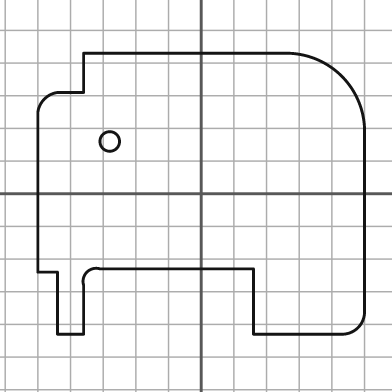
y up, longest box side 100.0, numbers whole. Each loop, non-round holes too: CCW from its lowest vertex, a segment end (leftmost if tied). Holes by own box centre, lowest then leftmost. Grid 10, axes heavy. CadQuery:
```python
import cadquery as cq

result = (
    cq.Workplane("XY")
    .moveTo(-44.0, -43.0)
    .lineTo(-36.0, -43.0)
    .lineTo(-36.0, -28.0)
    .threePointArc((-35.0, -24.0), (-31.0, -23.0))
    .lineTo(16.0, -23.0)
    .lineTo(16.0, -43.0)
    .lineTo(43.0, -43.0)
    .threePointArc((48.0, -41.0), (50.0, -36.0))
    .lineTo(50.0, 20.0)
    .threePointArc((43.0, 36.0), (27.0, 43.0))
    .lineTo(-36.0, 43.0)
    .lineTo(-36.0, 31.0)
    .lineTo(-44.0, 31.0)
    .threePointArc((-48.0, 29.0), (-50.0, 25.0))
    .lineTo(-50.0, -24.0)
    .lineTo(-44.0, -24.0)
    .close()
    .moveTo(-28.0, 16.0)
    .circle(3.0)
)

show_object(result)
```